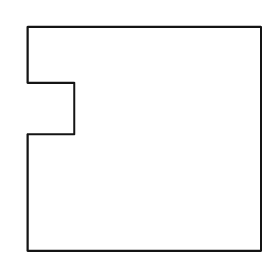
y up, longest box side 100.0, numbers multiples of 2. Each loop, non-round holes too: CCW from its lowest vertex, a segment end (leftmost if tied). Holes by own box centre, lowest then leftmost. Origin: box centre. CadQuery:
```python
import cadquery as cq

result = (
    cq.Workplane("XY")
    .moveTo(-50.0, -48.0)
    .lineTo(50.0, -48.0)
    .lineTo(50.0, 48.0)
    .lineTo(-50.0, 48.0)
    .lineTo(-50.0, 24.0)
    .lineTo(-30.0, 24.0)
    .lineTo(-30.0, 2.0)
    .lineTo(-50.0, 2.0)
    .close()
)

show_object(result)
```